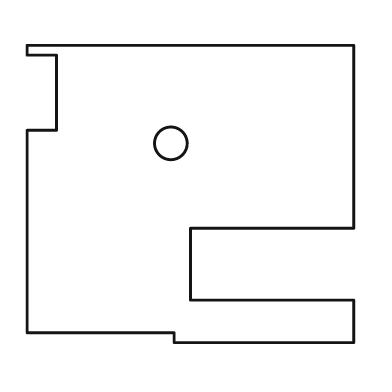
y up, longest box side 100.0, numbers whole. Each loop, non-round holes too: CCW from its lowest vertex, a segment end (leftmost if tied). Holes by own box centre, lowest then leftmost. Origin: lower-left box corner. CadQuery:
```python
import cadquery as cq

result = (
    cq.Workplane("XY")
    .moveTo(45.0, 0.0)
    .lineTo(100.0, 0.0)
    .lineTo(100.0, 13.0)
    .lineTo(50.0, 13.0)
    .lineTo(50.0, 35.0)
    .lineTo(100.0, 35.0)
    .lineTo(100.0, 91.0)
    .lineTo(0.0, 91.0)
    .lineTo(0.0, 88.0)
    .lineTo(9.0, 88.0)
    .lineTo(9.0, 65.0)
    .lineTo(0.0, 65.0)
    .lineTo(0.0, 3.0)
    .lineTo(45.0, 3.0)
    .close()
    .moveTo(44.0, 61.0)
    .circle(5.0)
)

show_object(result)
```